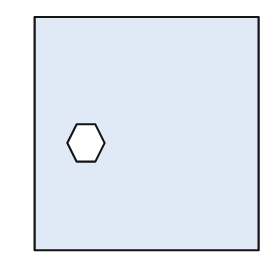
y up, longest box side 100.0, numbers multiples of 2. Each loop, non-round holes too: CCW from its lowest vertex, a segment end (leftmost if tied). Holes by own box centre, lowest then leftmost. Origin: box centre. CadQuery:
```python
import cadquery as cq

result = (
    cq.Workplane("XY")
    .moveTo(-48.0, -50.0)
    .lineTo(48.0, -50.0)
    .lineTo(48.0, 50.0)
    .lineTo(-48.0, 50.0)
    .close()
    .moveTo(-30.0, -12.0)
    .lineTo(-22.0, -12.0)
    .lineTo(-18.0, -4.0)
    .lineTo(-22.0, 4.0)
    .lineTo(-30.0, 4.0)
    .lineTo(-34.0, -4.0)
    .close()
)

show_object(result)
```